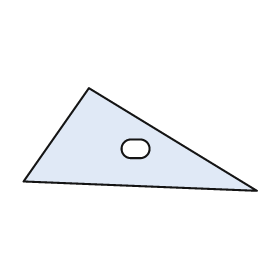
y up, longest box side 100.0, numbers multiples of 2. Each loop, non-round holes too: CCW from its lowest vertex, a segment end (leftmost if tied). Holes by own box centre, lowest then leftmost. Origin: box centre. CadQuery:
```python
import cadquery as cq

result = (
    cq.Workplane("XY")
    .moveTo(50.0, -22.0)
    .lineTo(-22.0, 22.0)
    .lineTo(-50.0, -18.0)
    .close()
    .moveTo(-4.0, -8.0)
    .lineTo(0.0, -8.0)
    .threePointArc((4.0, -4.0), (0.0, 0.0))
    .lineTo(-4.0, 0.0)
    .threePointArc((-8.0, -4.0), (-4.0, -8.0))
    .close()
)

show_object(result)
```